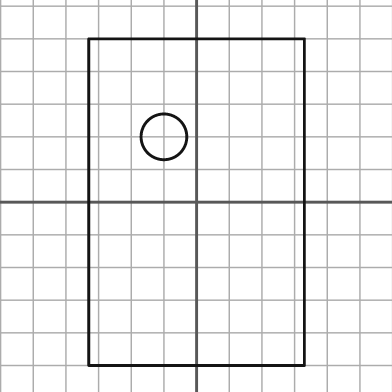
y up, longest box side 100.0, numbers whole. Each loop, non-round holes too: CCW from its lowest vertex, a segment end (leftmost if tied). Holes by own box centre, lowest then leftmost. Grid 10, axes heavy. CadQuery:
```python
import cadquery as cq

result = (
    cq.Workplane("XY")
    .moveTo(-33.0, -50.0)
    .lineTo(33.0, -50.0)
    .lineTo(33.0, 50.0)
    .lineTo(-33.0, 50.0)
    .close()
    .moveTo(-10.0, 20.0)
    .circle(7.0)
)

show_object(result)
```